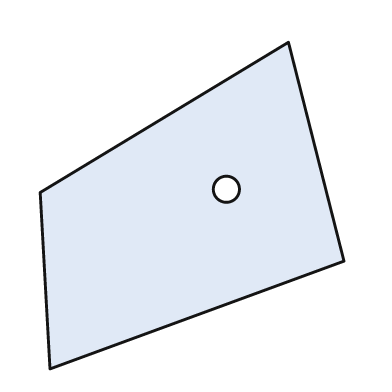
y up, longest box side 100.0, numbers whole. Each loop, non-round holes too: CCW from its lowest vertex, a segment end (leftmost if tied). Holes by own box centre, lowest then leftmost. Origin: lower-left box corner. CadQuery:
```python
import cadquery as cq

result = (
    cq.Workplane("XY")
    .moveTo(3.0, 0.0)
    .lineTo(93.0, 33.0)
    .lineTo(76.0, 100.0)
    .lineTo(0.0, 54.0)
    .close()
    .moveTo(57.0, 55.0)
    .circle(4.0)
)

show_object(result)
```